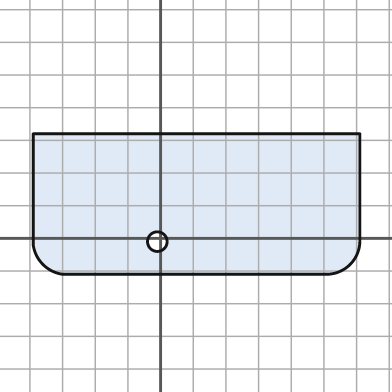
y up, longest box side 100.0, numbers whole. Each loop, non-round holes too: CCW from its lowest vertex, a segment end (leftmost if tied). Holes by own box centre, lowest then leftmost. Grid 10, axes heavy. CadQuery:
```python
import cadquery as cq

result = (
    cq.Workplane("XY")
    .moveTo(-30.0, -11.0)
    .lineTo(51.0, -11.0)
    .threePointArc((58.0, -8.0), (61.0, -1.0))
    .lineTo(61.0, 32.0)
    .lineTo(-39.0, 32.0)
    .lineTo(-39.0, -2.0)
    .threePointArc((-36.0, -8.0), (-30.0, -11.0))
    .close()
    .moveTo(-1.0, -1.0)
    .circle(3.0)
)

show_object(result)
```